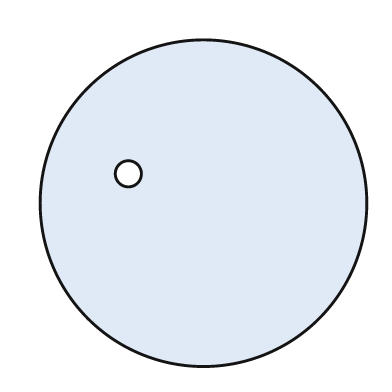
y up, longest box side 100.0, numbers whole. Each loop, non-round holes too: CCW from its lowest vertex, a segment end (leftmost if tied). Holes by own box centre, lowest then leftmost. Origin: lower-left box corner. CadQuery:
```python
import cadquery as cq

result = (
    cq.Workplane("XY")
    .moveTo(50.0, 50.0)
    .circle(50.0)
    .moveTo(27.0, 59.0)
    .circle(4.0)
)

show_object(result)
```